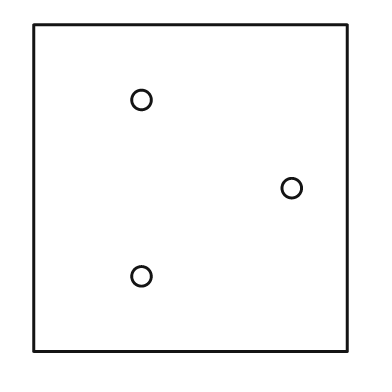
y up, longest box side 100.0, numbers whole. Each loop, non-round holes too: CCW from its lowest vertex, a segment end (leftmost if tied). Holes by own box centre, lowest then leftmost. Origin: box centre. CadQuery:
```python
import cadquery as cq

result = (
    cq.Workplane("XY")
    .moveTo(-48.0, -50.0)
    .lineTo(48.0, -50.0)
    .lineTo(48.0, 50.0)
    .lineTo(-48.0, 50.0)
    .close()
    .moveTo(-15.0, -27.0)
    .circle(3.0)
    .moveTo(31.0, 0.0)
    .circle(3.0)
    .moveTo(-15.0, 27.0)
    .circle(3.0)
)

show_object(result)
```